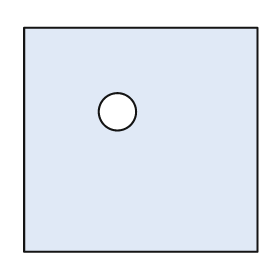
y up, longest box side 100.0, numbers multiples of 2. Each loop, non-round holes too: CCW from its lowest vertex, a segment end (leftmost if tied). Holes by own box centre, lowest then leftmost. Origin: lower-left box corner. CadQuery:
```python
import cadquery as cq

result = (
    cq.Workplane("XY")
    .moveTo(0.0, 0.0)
    .lineTo(100.0, 0.0)
    .lineTo(100.0, 96.0)
    .lineTo(0.0, 96.0)
    .close()
    .moveTo(40.0, 60.0)
    .circle(8.0)
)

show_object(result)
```